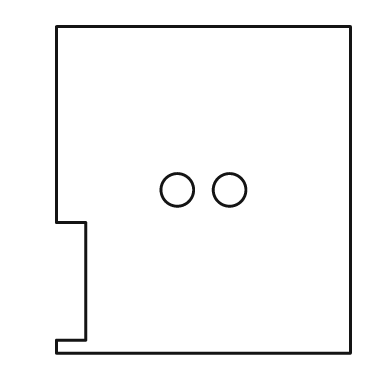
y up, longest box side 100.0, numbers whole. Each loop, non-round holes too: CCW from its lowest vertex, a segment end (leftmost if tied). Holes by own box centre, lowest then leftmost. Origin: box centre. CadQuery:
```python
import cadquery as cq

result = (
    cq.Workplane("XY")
    .moveTo(-45.0, -50.0)
    .lineTo(45.0, -50.0)
    .lineTo(45.0, 50.0)
    .lineTo(-45.0, 50.0)
    .lineTo(-45.0, -10.0)
    .lineTo(-36.0, -10.0)
    .lineTo(-36.0, -46.0)
    .lineTo(-45.0, -46.0)
    .close()
    .moveTo(-8.0, 0.0)
    .circle(5.0)
    .moveTo(8.0, 0.0)
    .circle(5.0)
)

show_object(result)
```